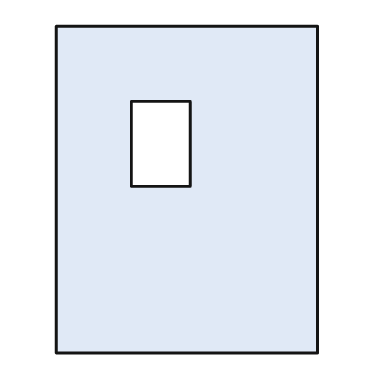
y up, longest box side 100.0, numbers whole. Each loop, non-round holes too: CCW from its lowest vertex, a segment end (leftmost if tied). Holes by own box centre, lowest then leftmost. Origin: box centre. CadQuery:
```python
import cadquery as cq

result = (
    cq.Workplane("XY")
    .moveTo(-40.0, -50.0)
    .lineTo(40.0, -50.0)
    .lineTo(40.0, 50.0)
    .lineTo(-40.0, 50.0)
    .close()
    .moveTo(-17.0, 1.0)
    .lineTo(1.0, 1.0)
    .lineTo(1.0, 27.0)
    .lineTo(-17.0, 27.0)
    .close()
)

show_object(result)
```